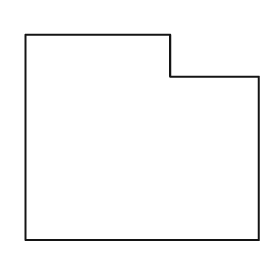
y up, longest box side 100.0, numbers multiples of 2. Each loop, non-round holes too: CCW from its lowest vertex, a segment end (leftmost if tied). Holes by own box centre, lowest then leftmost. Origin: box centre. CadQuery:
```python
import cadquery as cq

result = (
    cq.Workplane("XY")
    .moveTo(-50.0, -44.0)
    .lineTo(50.0, -44.0)
    .lineTo(50.0, 26.0)
    .lineTo(12.0, 26.0)
    .lineTo(12.0, 44.0)
    .lineTo(-50.0, 44.0)
    .close()
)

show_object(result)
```